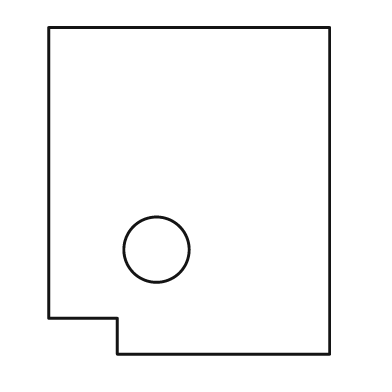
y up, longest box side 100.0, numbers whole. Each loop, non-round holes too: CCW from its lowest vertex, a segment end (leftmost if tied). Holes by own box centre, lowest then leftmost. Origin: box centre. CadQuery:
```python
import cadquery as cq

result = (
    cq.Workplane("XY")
    .moveTo(-22.0, -50.0)
    .lineTo(43.0, -50.0)
    .lineTo(43.0, 50.0)
    .lineTo(-43.0, 50.0)
    .lineTo(-43.0, -39.0)
    .lineTo(-22.0, -39.0)
    .close()
    .moveTo(-10.0, -18.0)
    .circle(10.0)
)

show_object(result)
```